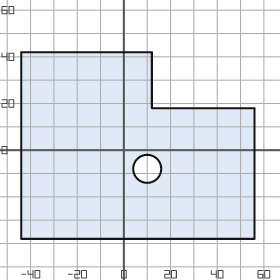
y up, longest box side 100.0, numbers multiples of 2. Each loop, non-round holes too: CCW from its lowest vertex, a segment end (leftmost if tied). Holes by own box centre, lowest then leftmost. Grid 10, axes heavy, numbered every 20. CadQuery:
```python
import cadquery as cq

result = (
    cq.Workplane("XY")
    .moveTo(-44.0, -38.0)
    .lineTo(56.0, -38.0)
    .lineTo(56.0, 18.0)
    .lineTo(12.0, 18.0)
    .lineTo(12.0, 42.0)
    .lineTo(-44.0, 42.0)
    .close()
    .moveTo(10.0, -8.0)
    .circle(6.0)
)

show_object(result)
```